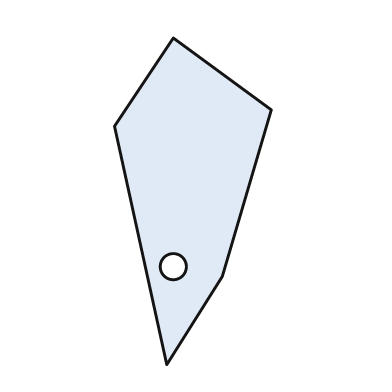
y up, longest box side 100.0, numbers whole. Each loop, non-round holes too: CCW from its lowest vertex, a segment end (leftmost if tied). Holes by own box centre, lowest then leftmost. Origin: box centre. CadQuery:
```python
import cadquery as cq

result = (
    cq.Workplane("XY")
    .moveTo(-8.0, -50.0)
    .lineTo(9.0, -23.0)
    .lineTo(24.0, 28.0)
    .lineTo(-6.0, 50.0)
    .lineTo(-24.0, 23.0)
    .close()
    .moveTo(-6.0, -20.0)
    .circle(4.0)
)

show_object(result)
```